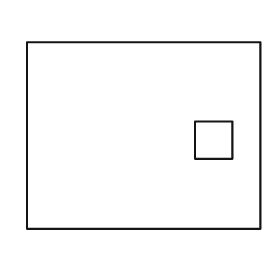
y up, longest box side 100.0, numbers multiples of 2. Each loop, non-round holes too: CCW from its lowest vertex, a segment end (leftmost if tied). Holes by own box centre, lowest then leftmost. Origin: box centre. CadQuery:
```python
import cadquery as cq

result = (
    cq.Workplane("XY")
    .moveTo(-50.0, -40.0)
    .lineTo(50.0, -40.0)
    .lineTo(50.0, 40.0)
    .lineTo(-50.0, 40.0)
    .close()
    .moveTo(22.0, -10.0)
    .lineTo(38.0, -10.0)
    .lineTo(38.0, 6.0)
    .lineTo(22.0, 6.0)
    .close()
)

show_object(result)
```